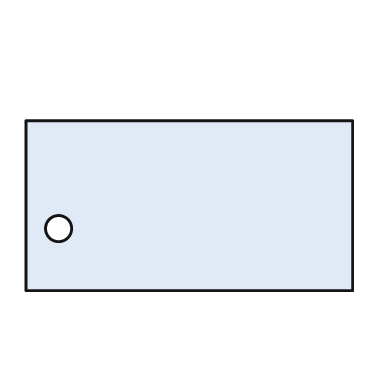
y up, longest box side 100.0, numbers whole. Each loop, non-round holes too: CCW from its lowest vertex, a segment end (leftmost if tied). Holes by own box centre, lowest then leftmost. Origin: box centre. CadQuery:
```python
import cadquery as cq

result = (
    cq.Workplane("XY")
    .moveTo(-50.0, -26.0)
    .lineTo(50.0, -26.0)
    .lineTo(50.0, 26.0)
    .lineTo(-50.0, 26.0)
    .close()
    .moveTo(-40.0, -7.0)
    .circle(4.0)
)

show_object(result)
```